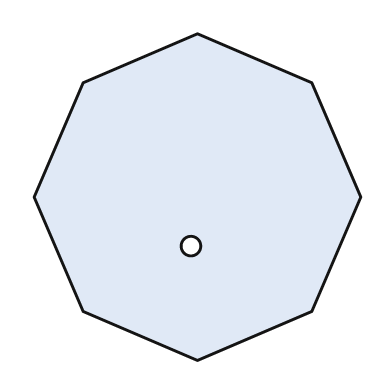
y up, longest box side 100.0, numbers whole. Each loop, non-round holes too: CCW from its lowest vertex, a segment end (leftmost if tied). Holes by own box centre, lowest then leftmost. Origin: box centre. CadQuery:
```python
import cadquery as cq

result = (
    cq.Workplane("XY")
    .moveTo(0.0, -50.0)
    .lineTo(35.0, -35.0)
    .lineTo(50.0, 0.0)
    .lineTo(35.0, 35.0)
    .lineTo(0.0, 50.0)
    .lineTo(-35.0, 35.0)
    .lineTo(-50.0, 0.0)
    .lineTo(-35.0, -35.0)
    .close()
    .moveTo(-2.0, -15.0)
    .circle(3.0)
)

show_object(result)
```